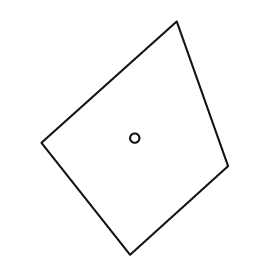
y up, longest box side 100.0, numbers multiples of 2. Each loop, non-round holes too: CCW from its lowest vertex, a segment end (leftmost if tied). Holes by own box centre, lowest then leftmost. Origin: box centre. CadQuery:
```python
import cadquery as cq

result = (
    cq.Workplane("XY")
    .moveTo(-2.0, -50.0)
    .lineTo(40.0, -12.0)
    .lineTo(18.0, 50.0)
    .lineTo(-40.0, -2.0)
    .close()
    .moveTo(0.0, 0.0)
    .circle(2.0)
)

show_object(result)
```